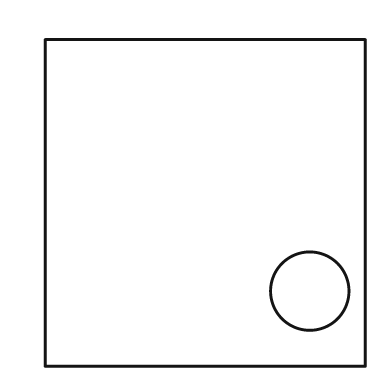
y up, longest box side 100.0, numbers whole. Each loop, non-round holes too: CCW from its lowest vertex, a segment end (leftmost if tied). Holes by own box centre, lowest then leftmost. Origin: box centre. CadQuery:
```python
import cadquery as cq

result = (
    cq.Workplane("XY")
    .moveTo(-49.0, -50.0)
    .lineTo(49.0, -50.0)
    .lineTo(49.0, 50.0)
    .lineTo(-49.0, 50.0)
    .close()
    .moveTo(32.0, -27.0)
    .circle(12.0)
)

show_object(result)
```